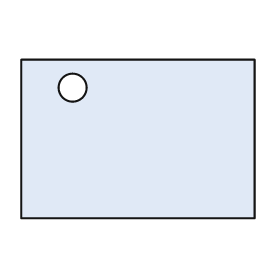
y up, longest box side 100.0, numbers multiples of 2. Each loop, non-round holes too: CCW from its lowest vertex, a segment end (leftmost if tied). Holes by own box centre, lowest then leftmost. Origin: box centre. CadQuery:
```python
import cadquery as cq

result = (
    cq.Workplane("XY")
    .moveTo(-50.0, -34.0)
    .lineTo(50.0, -34.0)
    .lineTo(50.0, 34.0)
    .lineTo(-50.0, 34.0)
    .close()
    .moveTo(-28.0, 22.0)
    .circle(6.0)
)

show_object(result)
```